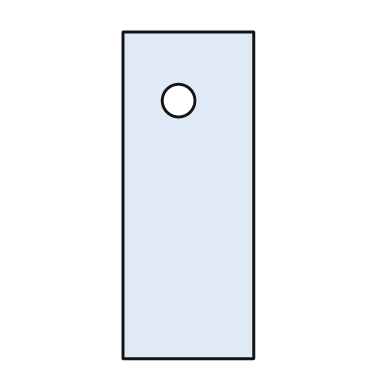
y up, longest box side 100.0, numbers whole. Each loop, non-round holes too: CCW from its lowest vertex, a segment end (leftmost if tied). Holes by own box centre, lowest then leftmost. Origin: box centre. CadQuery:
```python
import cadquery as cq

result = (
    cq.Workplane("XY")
    .moveTo(-20.0, -50.0)
    .lineTo(20.0, -50.0)
    .lineTo(20.0, 50.0)
    .lineTo(-20.0, 50.0)
    .close()
    .moveTo(-3.0, 29.0)
    .circle(5.0)
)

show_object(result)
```